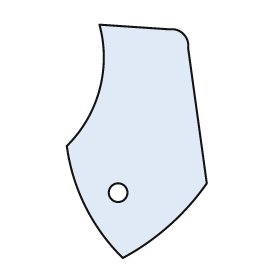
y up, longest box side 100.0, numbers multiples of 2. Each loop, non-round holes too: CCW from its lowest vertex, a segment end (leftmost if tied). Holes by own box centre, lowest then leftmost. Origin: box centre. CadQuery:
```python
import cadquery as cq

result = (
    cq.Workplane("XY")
    .moveTo(-6.0, -50.0)
    .threePointArc((14.0, -36.0), (30.0, -18.0))
    .lineTo(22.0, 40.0)
    .threePointArc((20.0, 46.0), (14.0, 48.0))
    .lineTo(-16.0, 50.0)
    .threePointArc((-16.0, 22.0), (-30.0, -2.0))
    .threePointArc((-22.0, -28.0), (-6.0, -50.0))
    .close()
    .moveTo(-8.0, -22.0)
    .circle(4.0)
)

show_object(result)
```